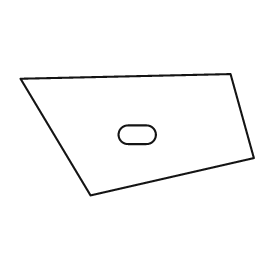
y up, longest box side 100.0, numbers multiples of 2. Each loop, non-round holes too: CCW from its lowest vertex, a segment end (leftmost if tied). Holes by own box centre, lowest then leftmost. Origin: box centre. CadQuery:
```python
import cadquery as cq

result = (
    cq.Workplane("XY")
    .moveTo(-20.0, -26.0)
    .lineTo(50.0, -10.0)
    .lineTo(40.0, 26.0)
    .lineTo(-50.0, 24.0)
    .close()
    .moveTo(-4.0, -4.0)
    .lineTo(4.0, -4.0)
    .threePointArc((8.0, 0.0), (4.0, 4.0))
    .lineTo(-4.0, 4.0)
    .threePointArc((-8.0, 0.0), (-4.0, -4.0))
    .close()
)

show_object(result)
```